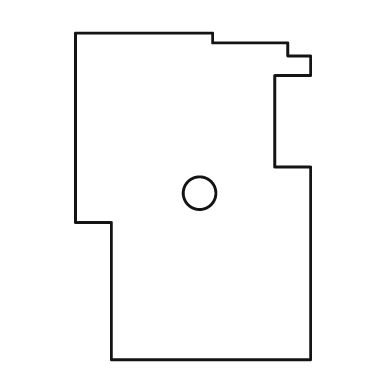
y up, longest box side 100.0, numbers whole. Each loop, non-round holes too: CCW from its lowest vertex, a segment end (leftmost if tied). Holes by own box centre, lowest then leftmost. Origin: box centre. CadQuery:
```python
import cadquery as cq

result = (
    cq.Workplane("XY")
    .moveTo(-25.0, -50.0)
    .lineTo(36.0, -50.0)
    .lineTo(36.0, 9.0)
    .lineTo(25.0, 9.0)
    .lineTo(25.0, 37.0)
    .lineTo(36.0, 37.0)
    .lineTo(36.0, 43.0)
    .lineTo(29.0, 43.0)
    .lineTo(29.0, 47.0)
    .lineTo(6.0, 47.0)
    .lineTo(6.0, 50.0)
    .lineTo(-36.0, 50.0)
    .lineTo(-36.0, -8.0)
    .lineTo(-25.0, -8.0)
    .close()
    .moveTo(2.0, 1.0)
    .circle(5.0)
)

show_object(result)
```